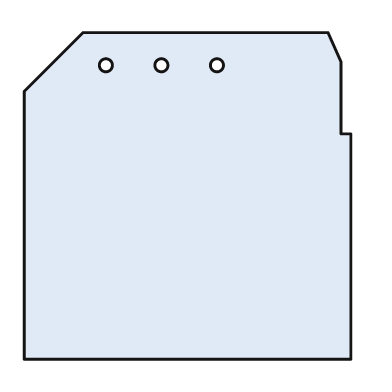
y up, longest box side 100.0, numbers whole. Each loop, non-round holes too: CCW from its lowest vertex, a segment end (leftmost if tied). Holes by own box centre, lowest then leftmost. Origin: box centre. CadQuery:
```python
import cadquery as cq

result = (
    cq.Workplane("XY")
    .moveTo(-50.0, -50.0)
    .lineTo(50.0, -50.0)
    .lineTo(50.0, 19.0)
    .lineTo(47.0, 19.0)
    .lineTo(47.0, 41.0)
    .lineTo(43.0, 50.0)
    .lineTo(-32.0, 50.0)
    .lineTo(-50.0, 32.0)
    .close()
    .moveTo(-25.0, 40.0)
    .circle(2.0)
    .moveTo(-8.0, 40.0)
    .circle(2.0)
    .moveTo(9.0, 40.0)
    .circle(2.0)
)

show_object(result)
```